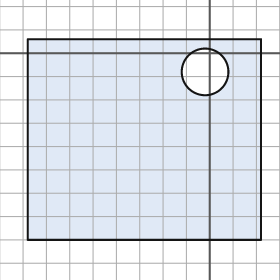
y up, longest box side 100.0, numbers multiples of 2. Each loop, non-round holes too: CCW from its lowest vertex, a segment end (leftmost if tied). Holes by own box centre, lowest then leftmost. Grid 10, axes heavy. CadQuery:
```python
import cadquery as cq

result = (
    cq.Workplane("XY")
    .moveTo(-78.0, -80.0)
    .lineTo(22.0, -80.0)
    .lineTo(22.0, 6.0)
    .lineTo(-78.0, 6.0)
    .close()
    .moveTo(-2.0, -8.0)
    .circle(10.0)
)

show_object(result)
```